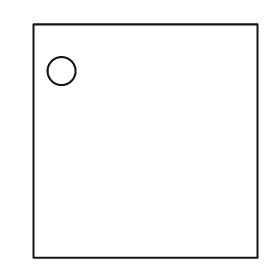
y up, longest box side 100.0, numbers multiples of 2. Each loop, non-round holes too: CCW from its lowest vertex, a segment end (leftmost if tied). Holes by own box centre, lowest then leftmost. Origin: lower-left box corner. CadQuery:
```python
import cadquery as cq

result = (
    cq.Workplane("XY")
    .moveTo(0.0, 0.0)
    .lineTo(96.0, 0.0)
    .lineTo(96.0, 100.0)
    .lineTo(0.0, 100.0)
    .close()
    .moveTo(12.0, 80.0)
    .circle(6.0)
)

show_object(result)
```